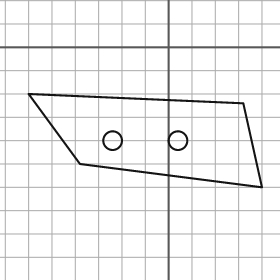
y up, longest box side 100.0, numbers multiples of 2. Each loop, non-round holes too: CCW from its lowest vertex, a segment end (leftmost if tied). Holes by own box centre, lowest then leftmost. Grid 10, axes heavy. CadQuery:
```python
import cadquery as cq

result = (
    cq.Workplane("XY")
    .moveTo(40.0, -60.0)
    .lineTo(32.0, -24.0)
    .lineTo(-60.0, -20.0)
    .lineTo(-38.0, -50.0)
    .close()
    .moveTo(-24.0, -40.0)
    .circle(4.0)
    .moveTo(4.0, -40.0)
    .circle(4.0)
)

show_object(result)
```